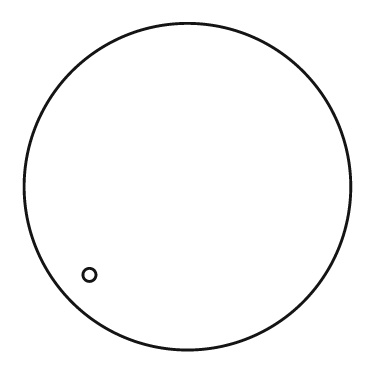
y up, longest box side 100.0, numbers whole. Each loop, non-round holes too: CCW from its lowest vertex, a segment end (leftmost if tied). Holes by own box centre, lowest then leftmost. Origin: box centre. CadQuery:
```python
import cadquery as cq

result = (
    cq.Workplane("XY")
    .moveTo(0.0, 0.0)
    .circle(50.0)
    .moveTo(-30.0, -27.0)
    .circle(2.0)
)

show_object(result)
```